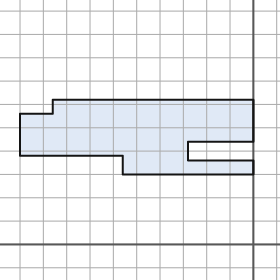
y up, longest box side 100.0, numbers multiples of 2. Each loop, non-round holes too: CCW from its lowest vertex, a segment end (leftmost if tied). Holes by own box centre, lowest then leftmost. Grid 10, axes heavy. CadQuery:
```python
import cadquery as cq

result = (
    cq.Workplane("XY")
    .moveTo(-56.0, 30.0)
    .lineTo(0.0, 30.0)
    .lineTo(0.0, 36.0)
    .lineTo(-28.0, 36.0)
    .lineTo(-28.0, 44.0)
    .lineTo(0.0, 44.0)
    .lineTo(0.0, 62.0)
    .lineTo(-86.0, 62.0)
    .lineTo(-86.0, 56.0)
    .lineTo(-100.0, 56.0)
    .lineTo(-100.0, 38.0)
    .lineTo(-56.0, 38.0)
    .close()
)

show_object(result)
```